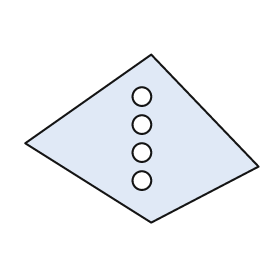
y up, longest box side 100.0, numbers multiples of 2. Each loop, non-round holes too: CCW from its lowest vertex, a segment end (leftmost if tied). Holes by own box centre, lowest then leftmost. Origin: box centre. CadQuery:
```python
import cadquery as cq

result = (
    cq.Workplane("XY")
    .moveTo(4.0, -36.0)
    .lineTo(50.0, -12.0)
    .lineTo(4.0, 36.0)
    .lineTo(-50.0, -2.0)
    .close()
    .moveTo(0.0, -18.0)
    .circle(4.0)
    .moveTo(0.0, -6.0)
    .circle(4.0)
    .moveTo(0.0, 6.0)
    .circle(4.0)
    .moveTo(0.0, 18.0)
    .circle(4.0)
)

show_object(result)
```